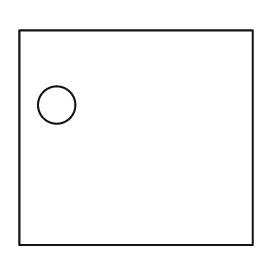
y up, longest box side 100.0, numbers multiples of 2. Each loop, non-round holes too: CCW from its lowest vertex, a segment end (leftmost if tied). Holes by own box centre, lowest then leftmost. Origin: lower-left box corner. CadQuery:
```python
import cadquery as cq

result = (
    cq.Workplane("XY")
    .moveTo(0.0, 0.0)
    .lineTo(100.0, 0.0)
    .lineTo(100.0, 92.0)
    .lineTo(0.0, 92.0)
    .close()
    .moveTo(16.0, 60.0)
    .circle(8.0)
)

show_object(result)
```